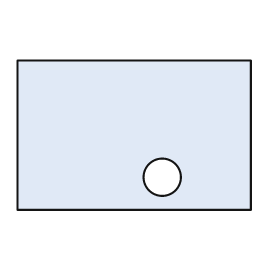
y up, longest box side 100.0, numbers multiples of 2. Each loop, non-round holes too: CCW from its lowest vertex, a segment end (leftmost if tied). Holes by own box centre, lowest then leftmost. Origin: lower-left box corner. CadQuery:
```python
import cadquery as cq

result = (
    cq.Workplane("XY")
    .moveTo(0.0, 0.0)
    .lineTo(100.0, 0.0)
    .lineTo(100.0, 64.0)
    .lineTo(0.0, 64.0)
    .close()
    .moveTo(62.0, 14.0)
    .circle(8.0)
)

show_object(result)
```